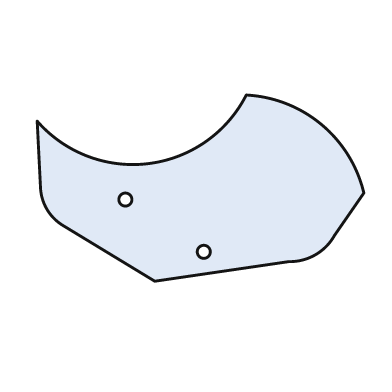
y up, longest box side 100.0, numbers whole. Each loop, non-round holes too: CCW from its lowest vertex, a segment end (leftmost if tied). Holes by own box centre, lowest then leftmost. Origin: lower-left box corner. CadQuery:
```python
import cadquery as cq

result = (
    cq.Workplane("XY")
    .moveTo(36.0, 0.0)
    .lineTo(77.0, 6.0)
    .threePointArc((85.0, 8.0), (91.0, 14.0))
    .lineTo(100.0, 27.0)
    .threePointArc((87.0, 48.0), (64.0, 57.0))
    .threePointArc((34.0, 36.0), (0.0, 49.0))
    .lineTo(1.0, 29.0)
    .threePointArc((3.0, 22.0), (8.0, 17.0))
    .close()
    .moveTo(51.0, 9.0)
    .circle(2.0)
    .moveTo(27.0, 25.0)
    .circle(2.0)
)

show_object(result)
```